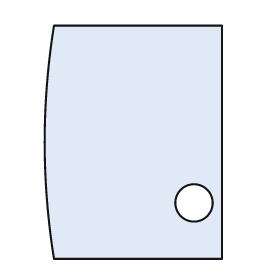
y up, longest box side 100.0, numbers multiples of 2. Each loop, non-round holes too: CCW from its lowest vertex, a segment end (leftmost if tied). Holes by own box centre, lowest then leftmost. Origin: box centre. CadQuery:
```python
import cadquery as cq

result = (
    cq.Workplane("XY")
    .moveTo(-34.0, -50.0)
    .lineTo(38.0, -50.0)
    .lineTo(38.0, 50.0)
    .lineTo(-34.0, 50.0)
    .threePointArc((-38.0, 0.0), (-34.0, -50.0))
    .close()
    .moveTo(26.0, -26.0)
    .circle(8.0)
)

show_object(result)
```